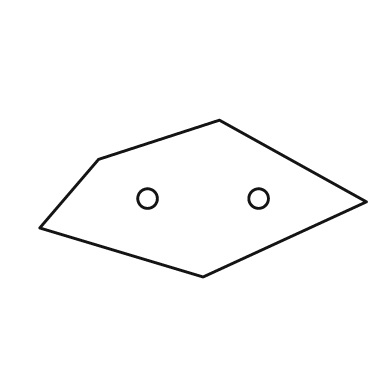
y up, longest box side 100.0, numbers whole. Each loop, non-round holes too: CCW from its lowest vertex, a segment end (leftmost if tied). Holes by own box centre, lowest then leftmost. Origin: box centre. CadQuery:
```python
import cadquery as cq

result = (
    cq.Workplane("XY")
    .moveTo(0.0, -24.0)
    .lineTo(50.0, -1.0)
    .lineTo(5.0, 24.0)
    .lineTo(-32.0, 12.0)
    .lineTo(-50.0, -9.0)
    .close()
    .moveTo(-17.0, 0.0)
    .circle(3.0)
    .moveTo(17.0, 0.0)
    .circle(3.0)
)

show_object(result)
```